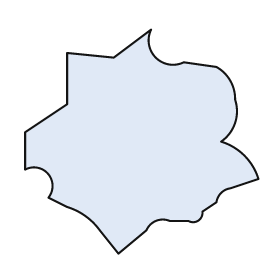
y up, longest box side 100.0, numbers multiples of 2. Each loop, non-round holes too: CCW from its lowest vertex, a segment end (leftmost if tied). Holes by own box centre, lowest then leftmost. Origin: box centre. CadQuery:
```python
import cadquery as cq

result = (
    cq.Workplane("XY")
    .moveTo(-10.0, -48.0)
    .lineTo(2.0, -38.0)
    .threePointArc((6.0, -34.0), (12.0, -34.0))
    .lineTo(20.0, -34.0)
    .threePointArc((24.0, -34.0), (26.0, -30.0))
    .lineTo(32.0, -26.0)
    .threePointArc((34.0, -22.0), (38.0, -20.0))
    .lineTo(50.0, -16.0)
    .threePointArc((44.0, -6.0), (34.0, 0.0))
    .threePointArc((40.0, 8.0), (40.0, 18.0))
    .threePointArc((38.0, 26.0), (32.0, 32.0))
    .lineTo(18.0, 34.0)
    .threePointArc((6.0, 36.0), (4.0, 48.0))
    .lineTo(-12.0, 36.0)
    .lineTo(-32.0, 38.0)
    .lineTo(-32.0, 16.0)
    .lineTo(-50.0, 4.0)
    .lineTo(-50.0, -12.0)
    .threePointArc((-40.0, -14.0), (-40.0, -24.0))
    .lineTo(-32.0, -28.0)
    .threePointArc((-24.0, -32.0), (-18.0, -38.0))
    .close()
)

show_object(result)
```